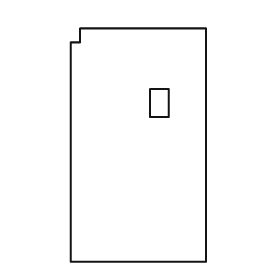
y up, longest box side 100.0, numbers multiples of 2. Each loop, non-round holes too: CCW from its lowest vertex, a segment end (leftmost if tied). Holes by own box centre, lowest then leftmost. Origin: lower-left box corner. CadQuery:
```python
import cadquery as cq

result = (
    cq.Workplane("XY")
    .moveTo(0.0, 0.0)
    .lineTo(58.0, 0.0)
    .lineTo(58.0, 100.0)
    .lineTo(4.0, 100.0)
    .lineTo(4.0, 94.0)
    .lineTo(0.0, 94.0)
    .close()
    .moveTo(34.0, 62.0)
    .lineTo(42.0, 62.0)
    .lineTo(42.0, 74.0)
    .lineTo(34.0, 74.0)
    .close()
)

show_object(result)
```